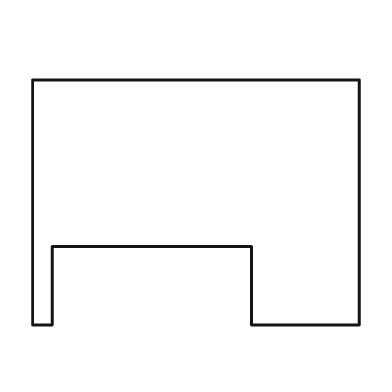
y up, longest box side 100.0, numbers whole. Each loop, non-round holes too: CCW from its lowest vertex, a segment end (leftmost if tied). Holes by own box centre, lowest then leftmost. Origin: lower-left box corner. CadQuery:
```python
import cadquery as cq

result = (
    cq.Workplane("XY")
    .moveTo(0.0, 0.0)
    .lineTo(6.0, 0.0)
    .lineTo(6.0, 24.0)
    .lineTo(67.0, 24.0)
    .lineTo(67.0, 0.0)
    .lineTo(100.0, 0.0)
    .lineTo(100.0, 75.0)
    .lineTo(0.0, 75.0)
    .close()
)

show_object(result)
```